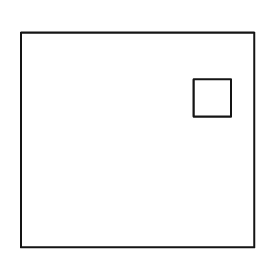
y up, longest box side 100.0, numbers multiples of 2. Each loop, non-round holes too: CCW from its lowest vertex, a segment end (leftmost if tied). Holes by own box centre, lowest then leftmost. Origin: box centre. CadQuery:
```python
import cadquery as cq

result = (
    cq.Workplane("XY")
    .moveTo(-50.0, -46.0)
    .lineTo(50.0, -46.0)
    .lineTo(50.0, 46.0)
    .lineTo(-50.0, 46.0)
    .close()
    .moveTo(24.0, 10.0)
    .lineTo(40.0, 10.0)
    .lineTo(40.0, 26.0)
    .lineTo(24.0, 26.0)
    .close()
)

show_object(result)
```